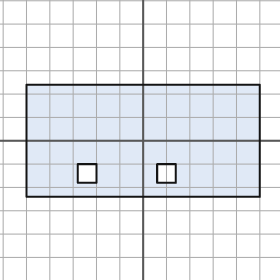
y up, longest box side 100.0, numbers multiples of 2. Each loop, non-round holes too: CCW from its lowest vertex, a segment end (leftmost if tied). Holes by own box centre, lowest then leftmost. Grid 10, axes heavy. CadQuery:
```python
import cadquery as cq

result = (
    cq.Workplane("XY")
    .moveTo(-50.0, -24.0)
    .lineTo(50.0, -24.0)
    .lineTo(50.0, 24.0)
    .lineTo(-50.0, 24.0)
    .close()
    .moveTo(-28.0, -18.0)
    .lineTo(-20.0, -18.0)
    .lineTo(-20.0, -10.0)
    .lineTo(-28.0, -10.0)
    .close()
    .moveTo(6.0, -18.0)
    .lineTo(14.0, -18.0)
    .lineTo(14.0, -10.0)
    .lineTo(6.0, -10.0)
    .close()
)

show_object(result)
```